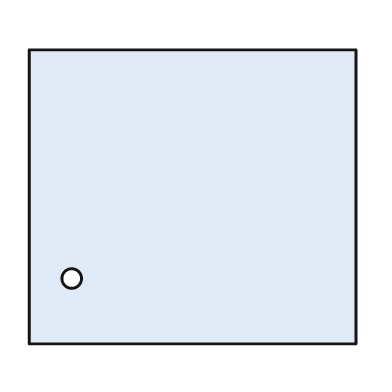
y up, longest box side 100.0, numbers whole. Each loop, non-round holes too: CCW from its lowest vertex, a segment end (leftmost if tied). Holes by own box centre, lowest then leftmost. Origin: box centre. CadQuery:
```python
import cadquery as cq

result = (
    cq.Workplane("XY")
    .moveTo(-50.0, -45.0)
    .lineTo(50.0, -45.0)
    .lineTo(50.0, 45.0)
    .lineTo(-50.0, 45.0)
    .close()
    .moveTo(-37.0, -25.0)
    .circle(3.0)
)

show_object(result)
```